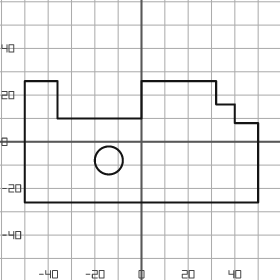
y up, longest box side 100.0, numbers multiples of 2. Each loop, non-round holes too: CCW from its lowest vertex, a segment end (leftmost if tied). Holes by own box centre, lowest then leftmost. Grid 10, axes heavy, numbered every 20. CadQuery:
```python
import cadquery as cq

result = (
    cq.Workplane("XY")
    .moveTo(-50.0, -26.0)
    .lineTo(50.0, -26.0)
    .lineTo(50.0, 8.0)
    .lineTo(40.0, 8.0)
    .lineTo(40.0, 16.0)
    .lineTo(32.0, 16.0)
    .lineTo(32.0, 26.0)
    .lineTo(0.0, 26.0)
    .lineTo(0.0, 10.0)
    .lineTo(-36.0, 10.0)
    .lineTo(-36.0, 26.0)
    .lineTo(-50.0, 26.0)
    .close()
    .moveTo(-14.0, -8.0)
    .circle(6.0)
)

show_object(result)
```